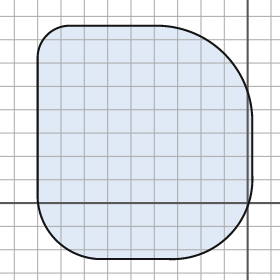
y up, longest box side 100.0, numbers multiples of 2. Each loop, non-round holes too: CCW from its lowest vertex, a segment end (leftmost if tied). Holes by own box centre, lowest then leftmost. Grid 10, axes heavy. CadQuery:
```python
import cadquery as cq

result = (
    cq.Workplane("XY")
    .moveTo(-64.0, -24.0)
    .lineTo(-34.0, -24.0)
    .threePointArc((-8.0, -14.0), (2.0, 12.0))
    .lineTo(2.0, 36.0)
    .threePointArc((-10.0, 64.0), (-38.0, 76.0))
    .lineTo(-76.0, 76.0)
    .threePointArc((-86.0, 72.0), (-90.0, 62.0))
    .lineTo(-90.0, 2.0)
    .threePointArc((-82.0, -16.0), (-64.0, -24.0))
    .close()
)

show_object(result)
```